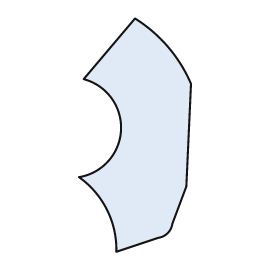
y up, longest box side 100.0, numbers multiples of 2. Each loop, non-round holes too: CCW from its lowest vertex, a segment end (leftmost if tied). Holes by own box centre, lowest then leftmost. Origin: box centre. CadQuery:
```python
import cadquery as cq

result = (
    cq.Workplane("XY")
    .moveTo(-8.0, -50.0)
    .lineTo(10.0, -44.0)
    .threePointArc((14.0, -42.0), (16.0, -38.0))
    .lineTo(22.0, -22.0)
    .lineTo(24.0, 22.0)
    .threePointArc((14.0, 38.0), (0.0, 50.0))
    .lineTo(-22.0, 24.0)
    .threePointArc((-6.0, 2.0), (-24.0, -18.0))
    .threePointArc((-12.0, -32.0), (-8.0, -50.0))
    .close()
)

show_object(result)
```